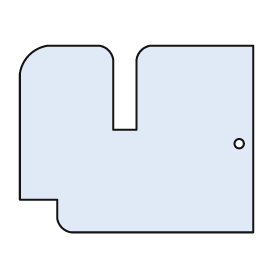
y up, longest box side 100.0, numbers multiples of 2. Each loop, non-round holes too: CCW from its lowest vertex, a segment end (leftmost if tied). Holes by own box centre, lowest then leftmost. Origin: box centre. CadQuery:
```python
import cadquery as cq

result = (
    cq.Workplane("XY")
    .moveTo(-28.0, -40.0)
    .lineTo(50.0, -40.0)
    .lineTo(50.0, 40.0)
    .lineTo(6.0, 40.0)
    .threePointArc((2.0, 38.0), (0.0, 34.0))
    .lineTo(0.0, 4.0)
    .lineTo(-10.0, 4.0)
    .lineTo(-10.0, 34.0)
    .threePointArc((-12.0, 38.0), (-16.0, 40.0))
    .lineTo(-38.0, 40.0)
    .threePointArc((-46.0, 36.0), (-50.0, 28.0))
    .lineTo(-50.0, -26.0)
    .lineTo(-34.0, -26.0)
    .lineTo(-34.0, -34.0)
    .threePointArc((-32.0, -38.0), (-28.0, -40.0))
    .close()
    .moveTo(44.0, -2.0)
    .circle(2.0)
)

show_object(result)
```